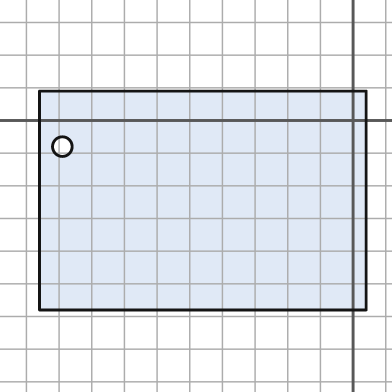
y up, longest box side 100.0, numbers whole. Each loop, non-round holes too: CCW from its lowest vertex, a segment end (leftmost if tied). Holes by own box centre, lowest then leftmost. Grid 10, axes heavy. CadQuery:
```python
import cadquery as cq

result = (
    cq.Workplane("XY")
    .moveTo(-96.0, -58.0)
    .lineTo(4.0, -58.0)
    .lineTo(4.0, 9.0)
    .lineTo(-96.0, 9.0)
    .close()
    .moveTo(-89.0, -8.0)
    .circle(3.0)
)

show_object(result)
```